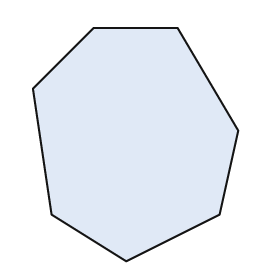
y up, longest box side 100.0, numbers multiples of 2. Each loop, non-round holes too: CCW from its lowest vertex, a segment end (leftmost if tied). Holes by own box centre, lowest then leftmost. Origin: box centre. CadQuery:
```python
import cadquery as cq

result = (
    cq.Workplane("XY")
    .moveTo(-4.0, -50.0)
    .lineTo(36.0, -30.0)
    .lineTo(44.0, 6.0)
    .lineTo(18.0, 50.0)
    .lineTo(-18.0, 50.0)
    .lineTo(-44.0, 24.0)
    .lineTo(-36.0, -30.0)
    .close()
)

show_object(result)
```